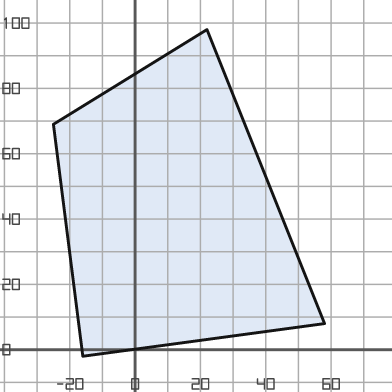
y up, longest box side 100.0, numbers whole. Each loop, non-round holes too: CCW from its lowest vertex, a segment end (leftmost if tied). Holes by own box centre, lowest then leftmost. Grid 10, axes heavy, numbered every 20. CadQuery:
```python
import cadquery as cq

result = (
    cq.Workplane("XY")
    .moveTo(-16.0, -2.0)
    .lineTo(58.0, 8.0)
    .lineTo(22.0, 98.0)
    .lineTo(-25.0, 69.0)
    .close()
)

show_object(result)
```